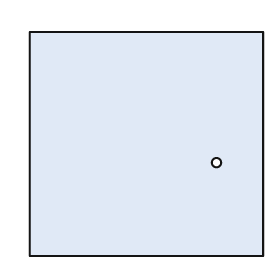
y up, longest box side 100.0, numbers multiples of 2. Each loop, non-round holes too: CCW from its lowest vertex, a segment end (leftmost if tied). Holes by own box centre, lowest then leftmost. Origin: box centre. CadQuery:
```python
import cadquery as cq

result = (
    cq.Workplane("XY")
    .moveTo(-50.0, -48.0)
    .lineTo(50.0, -48.0)
    .lineTo(50.0, 48.0)
    .lineTo(-50.0, 48.0)
    .close()
    .moveTo(30.0, -8.0)
    .circle(2.0)
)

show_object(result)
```